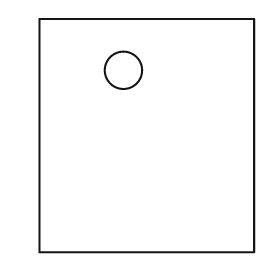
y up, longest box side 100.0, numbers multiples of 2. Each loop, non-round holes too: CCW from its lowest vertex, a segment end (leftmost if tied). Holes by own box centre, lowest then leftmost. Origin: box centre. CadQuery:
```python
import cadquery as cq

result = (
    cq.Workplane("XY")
    .moveTo(-46.0, -50.0)
    .lineTo(46.0, -50.0)
    .lineTo(46.0, 50.0)
    .lineTo(-46.0, 50.0)
    .close()
    .moveTo(-10.0, 28.0)
    .circle(8.0)
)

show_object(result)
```